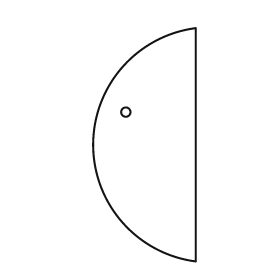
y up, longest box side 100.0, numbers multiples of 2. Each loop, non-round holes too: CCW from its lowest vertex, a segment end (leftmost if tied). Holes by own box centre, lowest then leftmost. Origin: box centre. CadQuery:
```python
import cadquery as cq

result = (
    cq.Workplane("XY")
    .moveTo(22.0, -50.0)
    .lineTo(22.0, 50.0)
    .threePointArc((-22.0, 0.0), (22.0, -50.0))
    .close()
    .moveTo(-8.0, 14.0)
    .circle(2.0)
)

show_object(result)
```